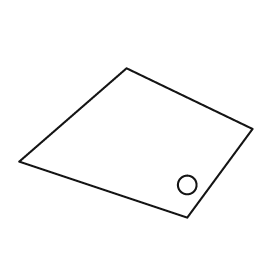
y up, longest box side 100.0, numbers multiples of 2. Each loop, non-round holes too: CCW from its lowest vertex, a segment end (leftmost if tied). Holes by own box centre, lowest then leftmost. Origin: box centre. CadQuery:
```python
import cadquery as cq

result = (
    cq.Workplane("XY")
    .moveTo(22.0, -32.0)
    .lineTo(50.0, 6.0)
    .lineTo(-4.0, 32.0)
    .lineTo(-50.0, -8.0)
    .close()
    .moveTo(22.0, -18.0)
    .circle(4.0)
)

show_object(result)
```